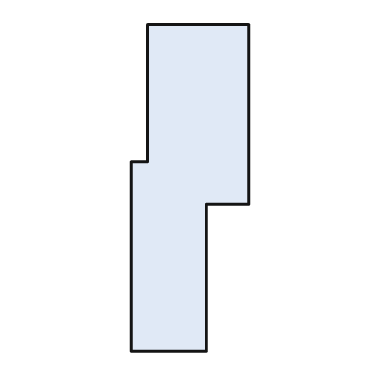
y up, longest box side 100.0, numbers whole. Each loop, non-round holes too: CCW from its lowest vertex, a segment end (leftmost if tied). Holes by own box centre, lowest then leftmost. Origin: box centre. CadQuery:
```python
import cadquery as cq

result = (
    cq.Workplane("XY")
    .moveTo(-18.0, -50.0)
    .lineTo(5.0, -50.0)
    .lineTo(5.0, -5.0)
    .lineTo(18.0, -5.0)
    .lineTo(18.0, 50.0)
    .lineTo(-13.0, 50.0)
    .lineTo(-13.0, 8.0)
    .lineTo(-18.0, 8.0)
    .close()
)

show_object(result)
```